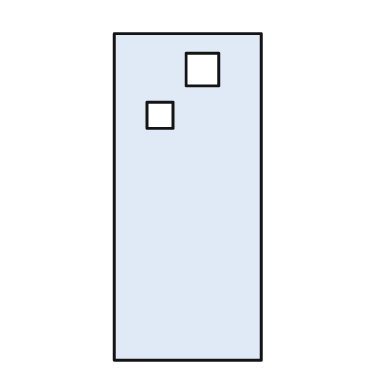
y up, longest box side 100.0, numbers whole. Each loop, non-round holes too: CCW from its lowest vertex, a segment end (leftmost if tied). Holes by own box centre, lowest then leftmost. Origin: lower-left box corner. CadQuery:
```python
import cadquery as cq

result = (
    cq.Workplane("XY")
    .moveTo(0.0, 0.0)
    .lineTo(45.0, 0.0)
    .lineTo(45.0, 100.0)
    .lineTo(0.0, 100.0)
    .close()
    .moveTo(10.0, 71.0)
    .lineTo(18.0, 71.0)
    .lineTo(18.0, 79.0)
    .lineTo(10.0, 79.0)
    .close()
    .moveTo(22.0, 84.0)
    .lineTo(32.0, 84.0)
    .lineTo(32.0, 94.0)
    .lineTo(22.0, 94.0)
    .close()
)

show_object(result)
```